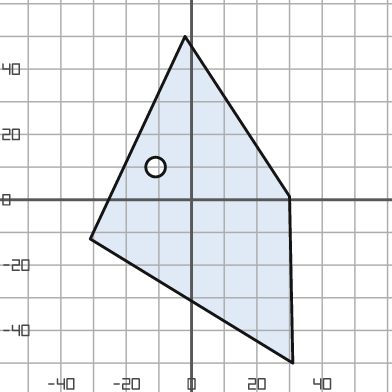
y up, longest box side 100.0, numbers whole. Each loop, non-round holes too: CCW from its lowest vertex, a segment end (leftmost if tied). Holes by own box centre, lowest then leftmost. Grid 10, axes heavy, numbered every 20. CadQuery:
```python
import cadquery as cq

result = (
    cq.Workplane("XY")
    .moveTo(31.0, -50.0)
    .lineTo(30.0, 1.0)
    .lineTo(-2.0, 50.0)
    .lineTo(-31.0, -12.0)
    .close()
    .moveTo(-11.0, 10.0)
    .circle(3.0)
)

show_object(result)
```